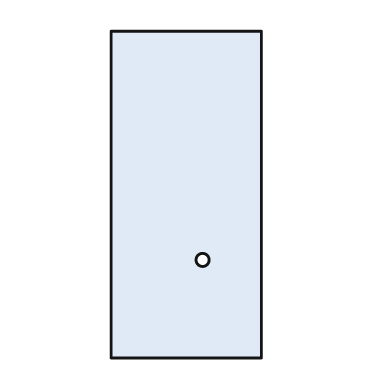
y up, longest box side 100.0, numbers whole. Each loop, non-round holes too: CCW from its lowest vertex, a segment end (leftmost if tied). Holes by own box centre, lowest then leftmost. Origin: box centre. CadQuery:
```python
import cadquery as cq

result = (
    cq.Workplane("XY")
    .moveTo(-23.0, -50.0)
    .lineTo(23.0, -50.0)
    .lineTo(23.0, 50.0)
    .lineTo(-23.0, 50.0)
    .close()
    .moveTo(5.0, -20.0)
    .circle(2.0)
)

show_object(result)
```